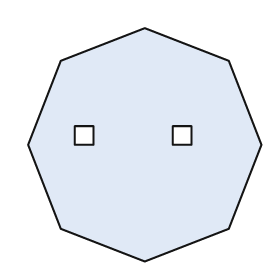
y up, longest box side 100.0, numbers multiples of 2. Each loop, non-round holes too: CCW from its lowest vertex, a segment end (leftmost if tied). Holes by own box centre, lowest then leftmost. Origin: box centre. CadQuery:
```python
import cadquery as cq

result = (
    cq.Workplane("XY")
    .moveTo(0.0, -50.0)
    .lineTo(36.0, -36.0)
    .lineTo(50.0, 0.0)
    .lineTo(36.0, 36.0)
    .lineTo(0.0, 50.0)
    .lineTo(-36.0, 36.0)
    .lineTo(-50.0, 0.0)
    .lineTo(-36.0, -36.0)
    .close()
    .moveTo(-30.0, 0.0)
    .lineTo(-22.0, 0.0)
    .lineTo(-22.0, 8.0)
    .lineTo(-30.0, 8.0)
    .close()
    .moveTo(12.0, 0.0)
    .lineTo(20.0, 0.0)
    .lineTo(20.0, 8.0)
    .lineTo(12.0, 8.0)
    .close()
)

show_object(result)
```